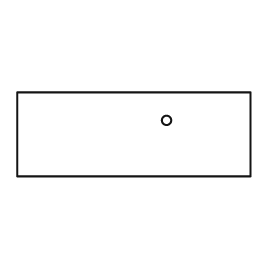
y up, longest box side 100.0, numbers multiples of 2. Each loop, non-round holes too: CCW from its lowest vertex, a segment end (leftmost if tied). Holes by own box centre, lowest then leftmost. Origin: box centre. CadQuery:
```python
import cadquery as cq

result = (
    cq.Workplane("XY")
    .moveTo(-50.0, -18.0)
    .lineTo(50.0, -18.0)
    .lineTo(50.0, 18.0)
    .lineTo(-50.0, 18.0)
    .close()
    .moveTo(14.0, 6.0)
    .circle(2.0)
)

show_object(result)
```